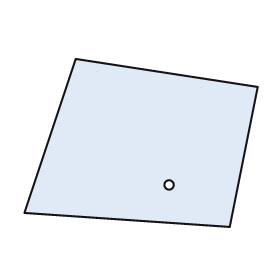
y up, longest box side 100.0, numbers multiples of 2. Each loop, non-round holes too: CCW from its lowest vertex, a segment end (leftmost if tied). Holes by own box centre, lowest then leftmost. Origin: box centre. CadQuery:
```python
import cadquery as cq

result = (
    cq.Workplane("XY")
    .moveTo(38.0, -36.0)
    .lineTo(50.0, 24.0)
    .lineTo(-28.0, 36.0)
    .lineTo(-50.0, -30.0)
    .close()
    .moveTo(12.0, -18.0)
    .circle(2.0)
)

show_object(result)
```